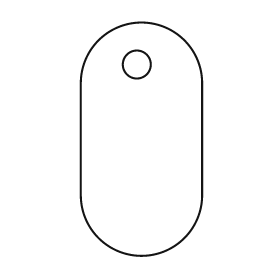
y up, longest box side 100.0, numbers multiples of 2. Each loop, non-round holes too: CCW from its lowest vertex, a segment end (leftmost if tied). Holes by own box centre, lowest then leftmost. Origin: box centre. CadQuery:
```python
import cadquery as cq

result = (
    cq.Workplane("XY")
    .moveTo(-26.0, -24.0)
    .threePointArc((0.0, -50.0), (26.0, -24.0))
    .lineTo(26.0, 24.0)
    .threePointArc((0.0, 50.0), (-26.0, 24.0))
    .close()
    .moveTo(-2.0, 32.0)
    .circle(6.0)
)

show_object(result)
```